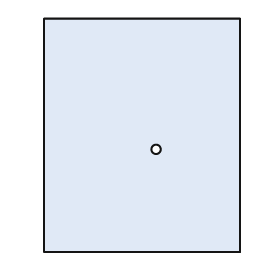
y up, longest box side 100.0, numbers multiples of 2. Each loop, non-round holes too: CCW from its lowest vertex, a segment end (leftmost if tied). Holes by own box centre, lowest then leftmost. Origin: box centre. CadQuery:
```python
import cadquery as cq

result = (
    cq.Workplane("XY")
    .moveTo(-42.0, -50.0)
    .lineTo(42.0, -50.0)
    .lineTo(42.0, 50.0)
    .lineTo(-42.0, 50.0)
    .close()
    .moveTo(6.0, -6.0)
    .circle(2.0)
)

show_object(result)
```